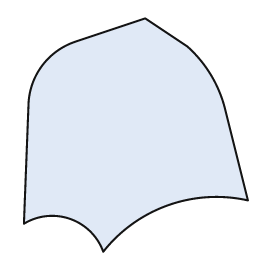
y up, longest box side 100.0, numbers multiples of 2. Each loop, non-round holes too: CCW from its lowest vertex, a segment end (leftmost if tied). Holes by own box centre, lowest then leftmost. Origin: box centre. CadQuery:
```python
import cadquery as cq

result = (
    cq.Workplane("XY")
    .moveTo(-14.0, -50.0)
    .threePointArc((14.0, -30.0), (48.0, -28.0))
    .lineTo(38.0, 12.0)
    .threePointArc((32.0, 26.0), (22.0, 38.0))
    .lineTo(4.0, 50.0)
    .lineTo(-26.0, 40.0)
    .threePointArc((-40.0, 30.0), (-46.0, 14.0))
    .lineTo(-48.0, -38.0)
    .threePointArc((-28.0, -36.0), (-14.0, -50.0))
    .close()
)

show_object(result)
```